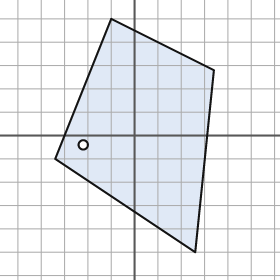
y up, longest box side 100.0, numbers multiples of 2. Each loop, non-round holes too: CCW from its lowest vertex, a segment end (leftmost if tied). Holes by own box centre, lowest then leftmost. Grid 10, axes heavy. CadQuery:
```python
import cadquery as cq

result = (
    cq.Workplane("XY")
    .moveTo(26.0, -50.0)
    .lineTo(34.0, 28.0)
    .lineTo(-10.0, 50.0)
    .lineTo(-34.0, -10.0)
    .close()
    .moveTo(-22.0, -4.0)
    .circle(2.0)
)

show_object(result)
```